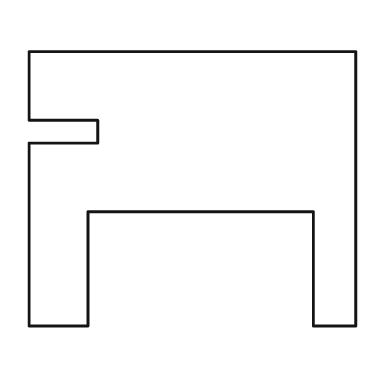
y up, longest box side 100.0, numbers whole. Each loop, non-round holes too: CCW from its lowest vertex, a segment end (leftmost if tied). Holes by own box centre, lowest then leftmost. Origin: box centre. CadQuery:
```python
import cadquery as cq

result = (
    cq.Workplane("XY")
    .moveTo(-50.0, -42.0)
    .lineTo(-32.0, -42.0)
    .lineTo(-32.0, -7.0)
    .lineTo(37.0, -7.0)
    .lineTo(37.0, -42.0)
    .lineTo(50.0, -42.0)
    .lineTo(50.0, 42.0)
    .lineTo(-50.0, 42.0)
    .lineTo(-50.0, 21.0)
    .lineTo(-29.0, 21.0)
    .lineTo(-29.0, 14.0)
    .lineTo(-50.0, 14.0)
    .close()
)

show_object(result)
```